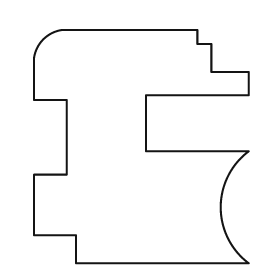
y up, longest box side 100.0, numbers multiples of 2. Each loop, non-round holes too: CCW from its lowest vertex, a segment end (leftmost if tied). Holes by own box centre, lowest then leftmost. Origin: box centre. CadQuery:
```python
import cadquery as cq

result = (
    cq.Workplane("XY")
    .moveTo(-28.0, -50.0)
    .lineTo(46.0, -50.0)
    .threePointArc((34.0, -26.0), (46.0, -2.0))
    .lineTo(2.0, -2.0)
    .lineTo(2.0, 22.0)
    .lineTo(46.0, 22.0)
    .lineTo(46.0, 32.0)
    .lineTo(30.0, 32.0)
    .lineTo(30.0, 44.0)
    .lineTo(24.0, 44.0)
    .lineTo(24.0, 50.0)
    .lineTo(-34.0, 50.0)
    .threePointArc((-42.0, 46.0), (-46.0, 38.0))
    .lineTo(-46.0, 20.0)
    .lineTo(-32.0, 20.0)
    .lineTo(-32.0, -12.0)
    .lineTo(-46.0, -12.0)
    .lineTo(-46.0, -38.0)
    .lineTo(-28.0, -38.0)
    .close()
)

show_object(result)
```